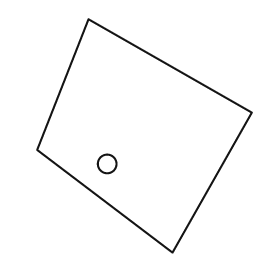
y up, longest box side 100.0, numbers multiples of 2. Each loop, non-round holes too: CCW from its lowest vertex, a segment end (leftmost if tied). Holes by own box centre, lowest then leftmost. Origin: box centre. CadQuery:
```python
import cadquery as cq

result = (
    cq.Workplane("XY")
    .moveTo(12.0, -50.0)
    .lineTo(46.0, 10.0)
    .lineTo(-24.0, 50.0)
    .lineTo(-46.0, -6.0)
    .close()
    .moveTo(-16.0, -12.0)
    .circle(4.0)
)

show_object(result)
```